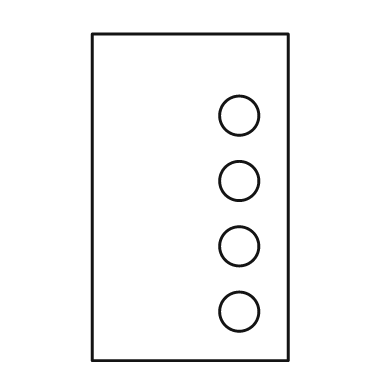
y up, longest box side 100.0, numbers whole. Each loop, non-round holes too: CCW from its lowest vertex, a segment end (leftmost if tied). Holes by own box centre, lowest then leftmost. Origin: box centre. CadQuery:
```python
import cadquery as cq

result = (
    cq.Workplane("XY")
    .moveTo(-30.0, -50.0)
    .lineTo(30.0, -50.0)
    .lineTo(30.0, 50.0)
    .lineTo(-30.0, 50.0)
    .close()
    .moveTo(15.0, -35.0)
    .circle(6.0)
    .moveTo(15.0, -15.0)
    .circle(6.0)
    .moveTo(15.0, 5.0)
    .circle(6.0)
    .moveTo(15.0, 25.0)
    .circle(6.0)
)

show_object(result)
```